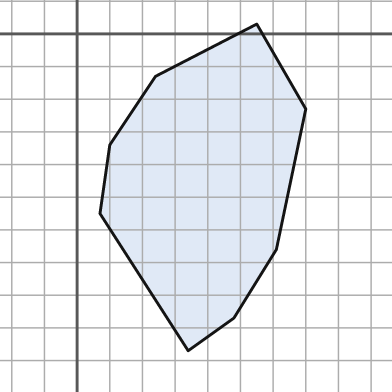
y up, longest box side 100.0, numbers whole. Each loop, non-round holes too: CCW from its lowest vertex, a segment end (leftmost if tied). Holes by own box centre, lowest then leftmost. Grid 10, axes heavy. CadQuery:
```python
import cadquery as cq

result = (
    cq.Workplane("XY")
    .moveTo(34.0, -97.0)
    .lineTo(48.0, -87.0)
    .lineTo(61.0, -66.0)
    .lineTo(70.0, -23.0)
    .lineTo(55.0, 3.0)
    .lineTo(24.0, -13.0)
    .lineTo(10.0, -34.0)
    .lineTo(7.0, -55.0)
    .close()
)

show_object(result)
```